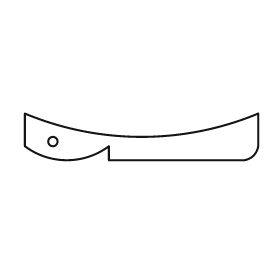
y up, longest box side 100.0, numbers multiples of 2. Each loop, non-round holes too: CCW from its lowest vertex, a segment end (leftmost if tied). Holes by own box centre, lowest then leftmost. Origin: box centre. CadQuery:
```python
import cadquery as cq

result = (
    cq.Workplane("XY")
    .moveTo(-14.0, -10.0)
    .lineTo(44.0, -10.0)
    .threePointArc((48.0, -8.0), (50.0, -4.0))
    .lineTo(50.0, 10.0)
    .threePointArc((0.0, 0.0), (-50.0, 10.0))
    .lineTo(-50.0, -4.0)
    .threePointArc((-32.0, -10.0), (-14.0, -4.0))
    .close()
    .moveTo(-38.0, -2.0)
    .circle(2.0)
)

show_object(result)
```